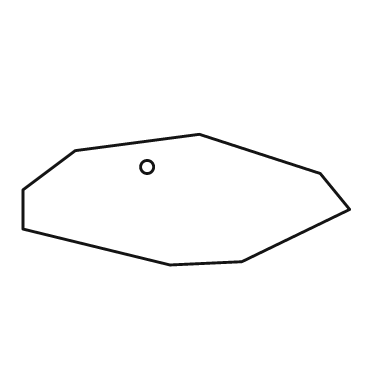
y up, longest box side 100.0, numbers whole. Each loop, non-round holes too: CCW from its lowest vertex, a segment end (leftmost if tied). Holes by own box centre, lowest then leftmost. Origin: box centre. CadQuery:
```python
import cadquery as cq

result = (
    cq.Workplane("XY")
    .moveTo(-5.0, -20.0)
    .lineTo(17.0, -19.0)
    .lineTo(50.0, -3.0)
    .lineTo(41.0, 8.0)
    .lineTo(4.0, 20.0)
    .lineTo(-34.0, 15.0)
    .lineTo(-50.0, 3.0)
    .lineTo(-50.0, -9.0)
    .close()
    .moveTo(-12.0, 10.0)
    .circle(2.0)
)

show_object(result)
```